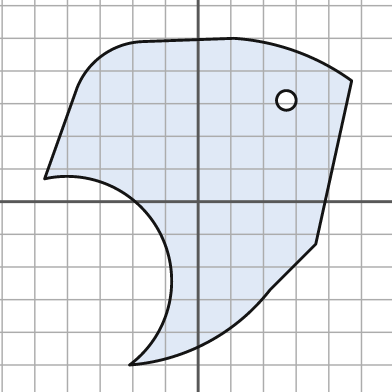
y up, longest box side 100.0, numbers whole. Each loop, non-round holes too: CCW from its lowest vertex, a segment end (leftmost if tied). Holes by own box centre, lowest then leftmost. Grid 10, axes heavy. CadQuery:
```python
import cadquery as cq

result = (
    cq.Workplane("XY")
    .moveTo(-21.0, -50.0)
    .threePointArc((3.0, -43.0), (22.0, -27.0))
    .lineTo(36.0, -13.0)
    .lineTo(47.0, 37.0)
    .threePointArc((30.0, 46.0), (11.0, 50.0))
    .lineTo(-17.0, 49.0)
    .threePointArc((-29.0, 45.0), (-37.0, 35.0))
    .lineTo(-47.0, 7.0)
    .threePointArc((-11.0, -11.0), (-21.0, -50.0))
    .close()
    .moveTo(27.0, 31.0)
    .circle(3.0)
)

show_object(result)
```